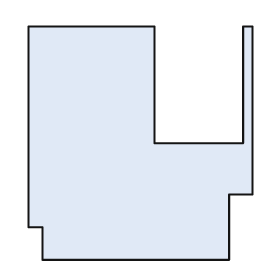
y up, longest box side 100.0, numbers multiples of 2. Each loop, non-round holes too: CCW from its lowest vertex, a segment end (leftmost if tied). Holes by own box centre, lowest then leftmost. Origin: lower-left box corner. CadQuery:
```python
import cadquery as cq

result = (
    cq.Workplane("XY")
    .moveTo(6.0, 0.0)
    .lineTo(86.0, 0.0)
    .lineTo(86.0, 28.0)
    .lineTo(96.0, 28.0)
    .lineTo(96.0, 100.0)
    .lineTo(92.0, 100.0)
    .lineTo(92.0, 50.0)
    .lineTo(54.0, 50.0)
    .lineTo(54.0, 100.0)
    .lineTo(0.0, 100.0)
    .lineTo(0.0, 14.0)
    .lineTo(6.0, 14.0)
    .close()
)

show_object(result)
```